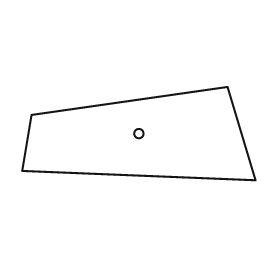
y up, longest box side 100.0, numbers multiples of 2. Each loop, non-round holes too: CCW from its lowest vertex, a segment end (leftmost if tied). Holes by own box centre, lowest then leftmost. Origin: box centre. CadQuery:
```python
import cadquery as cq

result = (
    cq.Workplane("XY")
    .moveTo(50.0, -20.0)
    .lineTo(38.0, 20.0)
    .lineTo(-46.0, 8.0)
    .lineTo(-50.0, -16.0)
    .close()
    .moveTo(0.0, 0.0)
    .circle(2.0)
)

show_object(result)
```